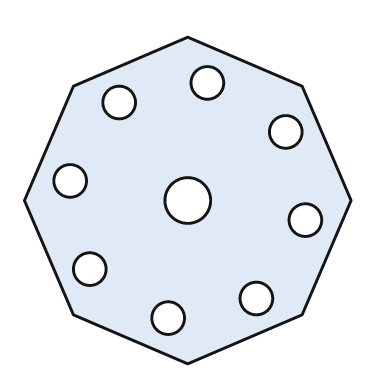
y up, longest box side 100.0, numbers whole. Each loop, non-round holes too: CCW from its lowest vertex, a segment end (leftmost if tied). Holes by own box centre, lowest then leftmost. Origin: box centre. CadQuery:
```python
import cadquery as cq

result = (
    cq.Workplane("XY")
    .moveTo(0.0, -50.0)
    .lineTo(35.0, -35.0)
    .lineTo(50.0, 0.0)
    .lineTo(35.0, 35.0)
    .lineTo(0.0, 50.0)
    .lineTo(-35.0, 35.0)
    .lineTo(-50.0, 0.0)
    .lineTo(-35.0, -35.0)
    .close()
    .moveTo(-6.0, -36.0)
    .circle(5.0)
    .moveTo(21.0, -30.0)
    .circle(5.0)
    .moveTo(-30.0, -21.0)
    .circle(5.0)
    .moveTo(36.0, -6.0)
    .circle(5.0)
    .moveTo(0.0, 0.0)
    .circle(7.0)
    .moveTo(-36.0, 6.0)
    .circle(5.0)
    .moveTo(30.0, 21.0)
    .circle(5.0)
    .moveTo(-21.0, 30.0)
    .circle(5.0)
    .moveTo(6.0, 36.0)
    .circle(5.0)
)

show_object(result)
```